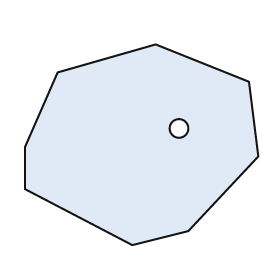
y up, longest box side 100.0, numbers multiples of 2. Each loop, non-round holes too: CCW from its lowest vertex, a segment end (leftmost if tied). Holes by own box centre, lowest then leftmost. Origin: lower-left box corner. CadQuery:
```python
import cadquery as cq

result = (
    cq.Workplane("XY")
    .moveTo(46.0, 0.0)
    .lineTo(70.0, 6.0)
    .lineTo(100.0, 38.0)
    .lineTo(96.0, 70.0)
    .lineTo(56.0, 86.0)
    .lineTo(14.0, 74.0)
    .lineTo(0.0, 42.0)
    .lineTo(0.0, 24.0)
    .close()
    .moveTo(66.0, 50.0)
    .circle(4.0)
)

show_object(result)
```